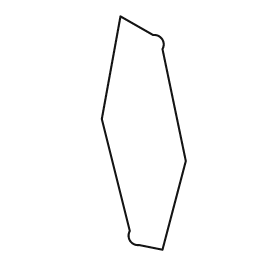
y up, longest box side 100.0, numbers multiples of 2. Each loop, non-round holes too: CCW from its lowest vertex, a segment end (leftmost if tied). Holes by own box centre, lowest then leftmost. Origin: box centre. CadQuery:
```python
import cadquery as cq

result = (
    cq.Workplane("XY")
    .moveTo(8.0, -50.0)
    .lineTo(18.0, -12.0)
    .lineTo(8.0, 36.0)
    .threePointArc((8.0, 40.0), (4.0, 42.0))
    .lineTo(-10.0, 50.0)
    .lineTo(-18.0, 6.0)
    .lineTo(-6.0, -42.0)
    .threePointArc((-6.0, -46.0), (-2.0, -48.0))
    .close()
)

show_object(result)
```